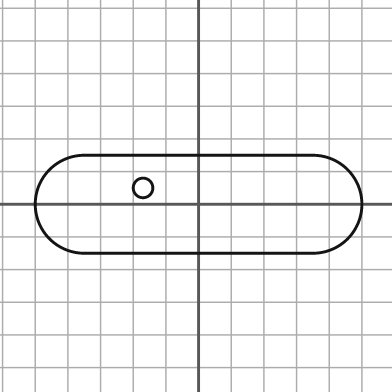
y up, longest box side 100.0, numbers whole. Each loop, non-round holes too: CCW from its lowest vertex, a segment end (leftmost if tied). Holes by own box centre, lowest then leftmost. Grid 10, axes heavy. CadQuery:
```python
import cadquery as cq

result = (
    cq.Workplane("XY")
    .moveTo(-35.0, -15.0)
    .lineTo(35.0, -15.0)
    .threePointArc((50.0, 0.0), (35.0, 15.0))
    .lineTo(-35.0, 15.0)
    .threePointArc((-50.0, 0.0), (-35.0, -15.0))
    .close()
    .moveTo(-17.0, 5.0)
    .circle(3.0)
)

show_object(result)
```